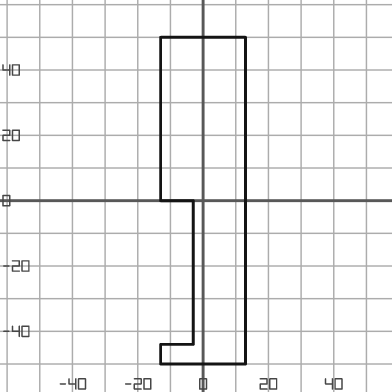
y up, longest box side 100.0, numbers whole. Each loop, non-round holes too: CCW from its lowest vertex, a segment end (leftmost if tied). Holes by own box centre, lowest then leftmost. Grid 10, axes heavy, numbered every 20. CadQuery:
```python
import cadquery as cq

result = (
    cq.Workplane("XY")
    .moveTo(-13.0, -50.0)
    .lineTo(13.0, -50.0)
    .lineTo(13.0, 50.0)
    .lineTo(-13.0, 50.0)
    .lineTo(-13.0, 0.0)
    .lineTo(-3.0, 0.0)
    .lineTo(-3.0, -44.0)
    .lineTo(-13.0, -44.0)
    .close()
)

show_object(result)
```